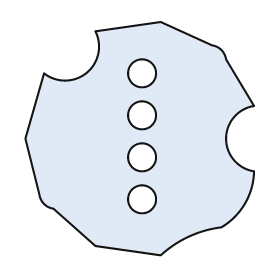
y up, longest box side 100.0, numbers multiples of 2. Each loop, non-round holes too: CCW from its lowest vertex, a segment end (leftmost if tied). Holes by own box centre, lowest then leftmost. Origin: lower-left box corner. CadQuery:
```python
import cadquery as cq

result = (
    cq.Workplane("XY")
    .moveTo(58.0, 0.0)
    .threePointArc((70.0, 8.0), (84.0, 12.0))
    .threePointArc((94.0, 22.0), (98.0, 36.0))
    .threePointArc((86.0, 50.0), (98.0, 64.0))
    .lineTo(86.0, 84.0)
    .threePointArc((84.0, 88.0), (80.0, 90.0))
    .lineTo(58.0, 100.0)
    .lineTo(30.0, 96.0)
    .threePointArc((26.0, 78.0), (8.0, 78.0))
    .lineTo(0.0, 50.0)
    .lineTo(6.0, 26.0)
    .threePointArc((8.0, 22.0), (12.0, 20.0))
    .lineTo(30.0, 4.0)
    .close()
    .moveTo(50.0, 24.0)
    .circle(6.0)
    .moveTo(50.0, 42.0)
    .circle(6.0)
    .moveTo(50.0, 60.0)
    .circle(6.0)
    .moveTo(50.0, 78.0)
    .circle(6.0)
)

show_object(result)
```